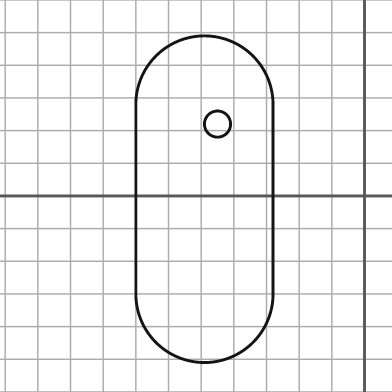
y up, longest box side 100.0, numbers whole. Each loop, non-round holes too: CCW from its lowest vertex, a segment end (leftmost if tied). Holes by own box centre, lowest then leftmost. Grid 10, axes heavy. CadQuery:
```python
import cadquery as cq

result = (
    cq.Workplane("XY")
    .moveTo(-70.0, -30.0)
    .threePointArc((-49.0, -51.0), (-28.0, -30.0))
    .lineTo(-28.0, 28.0)
    .threePointArc((-49.0, 49.0), (-70.0, 28.0))
    .close()
    .moveTo(-45.0, 22.0)
    .circle(4.0)
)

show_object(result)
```